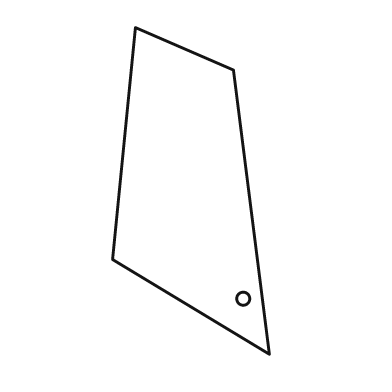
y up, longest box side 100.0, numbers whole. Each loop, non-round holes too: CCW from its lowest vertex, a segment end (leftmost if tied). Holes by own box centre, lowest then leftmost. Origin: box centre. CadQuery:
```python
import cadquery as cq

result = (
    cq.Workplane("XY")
    .moveTo(24.0, -50.0)
    .lineTo(13.0, 37.0)
    .lineTo(-17.0, 50.0)
    .lineTo(-24.0, -21.0)
    .close()
    .moveTo(16.0, -33.0)
    .circle(2.0)
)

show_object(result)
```